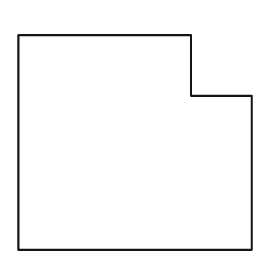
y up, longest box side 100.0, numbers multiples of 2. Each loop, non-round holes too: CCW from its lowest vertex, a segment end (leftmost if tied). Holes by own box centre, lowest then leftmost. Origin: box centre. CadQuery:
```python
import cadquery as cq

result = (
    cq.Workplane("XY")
    .moveTo(-50.0, -46.0)
    .lineTo(50.0, -46.0)
    .lineTo(50.0, 20.0)
    .lineTo(24.0, 20.0)
    .lineTo(24.0, 46.0)
    .lineTo(-50.0, 46.0)
    .close()
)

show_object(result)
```